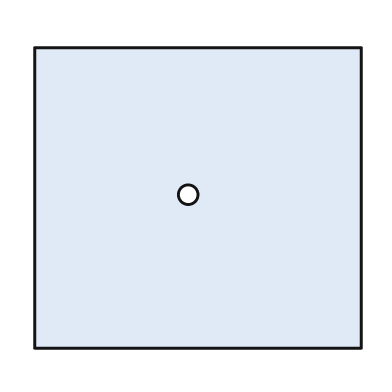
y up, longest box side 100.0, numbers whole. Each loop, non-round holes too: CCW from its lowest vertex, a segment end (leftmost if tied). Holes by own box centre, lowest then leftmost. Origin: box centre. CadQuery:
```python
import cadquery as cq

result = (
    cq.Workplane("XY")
    .moveTo(-50.0, -46.0)
    .lineTo(50.0, -46.0)
    .lineTo(50.0, 46.0)
    .lineTo(-50.0, 46.0)
    .close()
    .moveTo(-3.0, 1.0)
    .circle(3.0)
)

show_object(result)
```